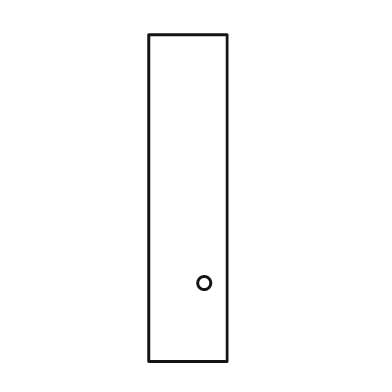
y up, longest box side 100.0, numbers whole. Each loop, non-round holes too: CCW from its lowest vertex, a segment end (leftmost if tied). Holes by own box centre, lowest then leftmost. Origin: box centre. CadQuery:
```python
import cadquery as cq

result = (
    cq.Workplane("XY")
    .moveTo(-12.0, -50.0)
    .lineTo(12.0, -50.0)
    .lineTo(12.0, 50.0)
    .lineTo(-12.0, 50.0)
    .close()
    .moveTo(5.0, -26.0)
    .circle(2.0)
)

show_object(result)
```